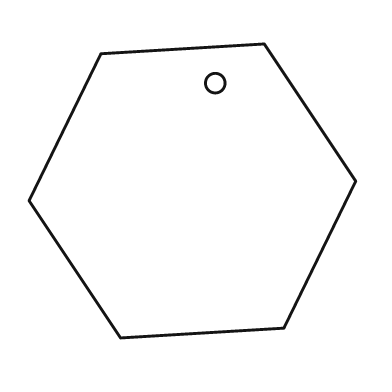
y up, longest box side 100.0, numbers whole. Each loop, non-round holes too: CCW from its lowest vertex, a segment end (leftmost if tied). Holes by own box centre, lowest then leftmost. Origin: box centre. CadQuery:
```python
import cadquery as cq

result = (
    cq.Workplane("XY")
    .moveTo(-22.0, -45.0)
    .lineTo(28.0, -42.0)
    .lineTo(50.0, 3.0)
    .lineTo(22.0, 45.0)
    .lineTo(-28.0, 42.0)
    .lineTo(-50.0, -3.0)
    .close()
    .moveTo(7.0, 33.0)
    .circle(3.0)
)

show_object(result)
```